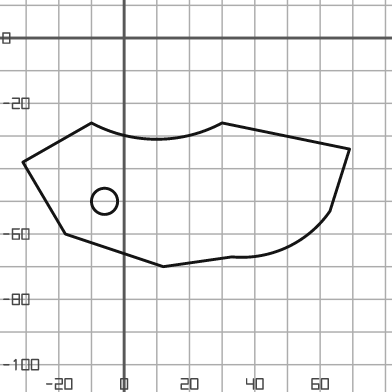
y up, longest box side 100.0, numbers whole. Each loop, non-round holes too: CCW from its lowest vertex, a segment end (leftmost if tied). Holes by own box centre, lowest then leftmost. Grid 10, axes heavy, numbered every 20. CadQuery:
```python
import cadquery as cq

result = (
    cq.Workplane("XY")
    .moveTo(12.0, -70.0)
    .lineTo(33.0, -67.0)
    .threePointArc((50.0, -64.0), (63.0, -53.0))
    .lineTo(69.0, -34.0)
    .lineTo(30.0, -26.0)
    .threePointArc((10.0, -31.0), (-10.0, -26.0))
    .lineTo(-31.0, -38.0)
    .lineTo(-18.0, -60.0)
    .close()
    .moveTo(-6.0, -50.0)
    .circle(4.0)
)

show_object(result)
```